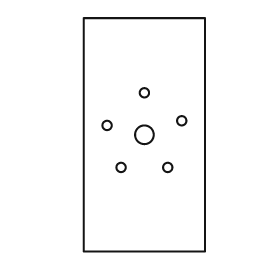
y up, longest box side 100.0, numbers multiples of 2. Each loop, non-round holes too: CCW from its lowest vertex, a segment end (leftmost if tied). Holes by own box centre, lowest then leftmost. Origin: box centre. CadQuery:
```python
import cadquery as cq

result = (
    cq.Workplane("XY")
    .moveTo(-26.0, -50.0)
    .lineTo(26.0, -50.0)
    .lineTo(26.0, 50.0)
    .lineTo(-26.0, 50.0)
    .close()
    .moveTo(-10.0, -14.0)
    .circle(2.0)
    .moveTo(10.0, -14.0)
    .circle(2.0)
    .moveTo(0.0, 0.0)
    .circle(4.0)
    .moveTo(-16.0, 4.0)
    .circle(2.0)
    .moveTo(16.0, 6.0)
    .circle(2.0)
    .moveTo(0.0, 18.0)
    .circle(2.0)
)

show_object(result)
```